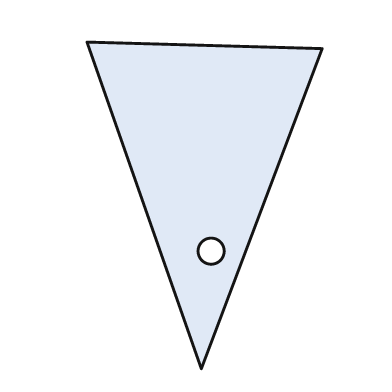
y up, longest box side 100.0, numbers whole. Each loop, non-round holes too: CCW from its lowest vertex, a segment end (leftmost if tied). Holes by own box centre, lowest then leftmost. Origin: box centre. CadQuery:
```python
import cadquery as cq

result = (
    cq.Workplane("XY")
    .moveTo(-1.0, -50.0)
    .lineTo(36.0, 48.0)
    .lineTo(-36.0, 50.0)
    .close()
    .moveTo(2.0, -14.0)
    .circle(4.0)
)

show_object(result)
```